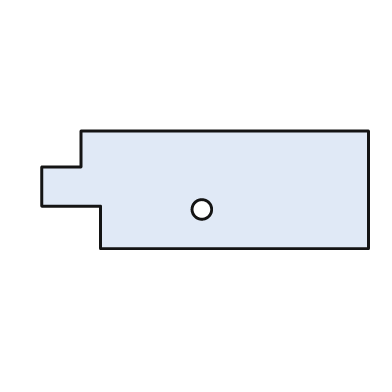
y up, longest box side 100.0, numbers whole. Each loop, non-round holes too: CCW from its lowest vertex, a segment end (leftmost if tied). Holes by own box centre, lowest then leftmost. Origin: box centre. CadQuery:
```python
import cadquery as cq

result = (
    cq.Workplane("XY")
    .moveTo(-32.0, -18.0)
    .lineTo(50.0, -18.0)
    .lineTo(50.0, 18.0)
    .lineTo(-38.0, 18.0)
    .lineTo(-38.0, 7.0)
    .lineTo(-50.0, 7.0)
    .lineTo(-50.0, -5.0)
    .lineTo(-32.0, -5.0)
    .close()
    .moveTo(-1.0, -6.0)
    .circle(3.0)
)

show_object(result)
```